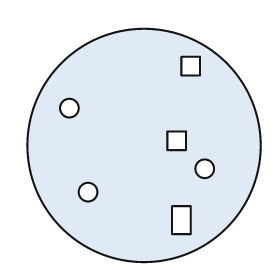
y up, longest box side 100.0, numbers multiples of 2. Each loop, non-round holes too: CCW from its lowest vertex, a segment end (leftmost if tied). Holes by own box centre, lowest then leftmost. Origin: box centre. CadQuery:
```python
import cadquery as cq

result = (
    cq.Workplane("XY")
    .moveTo(0.0, 0.0)
    .circle(50.0)
    .moveTo(12.0, -38.0)
    .lineTo(20.0, -38.0)
    .lineTo(20.0, -26.0)
    .lineTo(12.0, -26.0)
    .close()
    .moveTo(-24.0, -20.0)
    .circle(4.0)
    .moveTo(26.0, -10.0)
    .circle(4.0)
    .moveTo(10.0, -2.0)
    .lineTo(18.0, -2.0)
    .lineTo(18.0, 6.0)
    .lineTo(10.0, 6.0)
    .close()
    .moveTo(-32.0, 16.0)
    .circle(4.0)
    .moveTo(16.0, 30.0)
    .lineTo(24.0, 30.0)
    .lineTo(24.0, 38.0)
    .lineTo(16.0, 38.0)
    .close()
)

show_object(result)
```